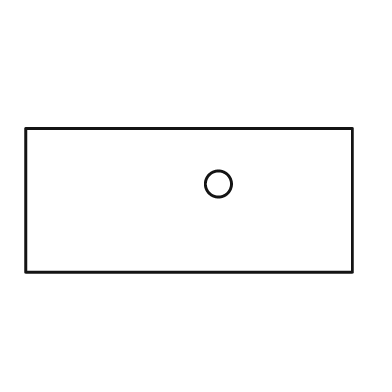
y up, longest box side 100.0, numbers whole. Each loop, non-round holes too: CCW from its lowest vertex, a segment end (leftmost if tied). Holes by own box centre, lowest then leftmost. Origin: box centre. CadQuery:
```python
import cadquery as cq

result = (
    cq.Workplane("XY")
    .moveTo(-50.0, -22.0)
    .lineTo(50.0, -22.0)
    .lineTo(50.0, 22.0)
    .lineTo(-50.0, 22.0)
    .close()
    .moveTo(9.0, 5.0)
    .circle(4.0)
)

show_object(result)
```